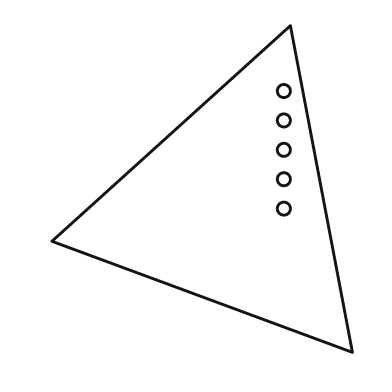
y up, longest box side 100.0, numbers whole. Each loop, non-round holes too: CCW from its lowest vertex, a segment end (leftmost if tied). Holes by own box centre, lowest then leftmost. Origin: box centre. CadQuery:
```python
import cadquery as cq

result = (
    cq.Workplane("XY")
    .moveTo(46.0, -50.0)
    .lineTo(27.0, 50.0)
    .lineTo(-46.0, -16.0)
    .close()
    .moveTo(25.0, -6.0)
    .circle(2.0)
    .moveTo(25.0, 3.0)
    .circle(2.0)
    .moveTo(25.0, 12.0)
    .circle(2.0)
    .moveTo(25.0, 21.0)
    .circle(2.0)
    .moveTo(25.0, 30.0)
    .circle(2.0)
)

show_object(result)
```